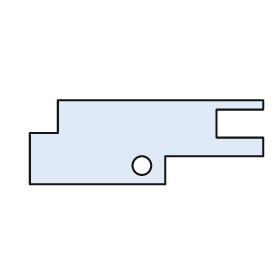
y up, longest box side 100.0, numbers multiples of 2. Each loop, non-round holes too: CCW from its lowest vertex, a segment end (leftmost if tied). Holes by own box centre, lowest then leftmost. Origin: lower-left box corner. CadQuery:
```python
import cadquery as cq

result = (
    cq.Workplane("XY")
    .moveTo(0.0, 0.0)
    .lineTo(58.0, 0.0)
    .lineTo(58.0, 12.0)
    .lineTo(100.0, 12.0)
    .lineTo(100.0, 20.0)
    .lineTo(80.0, 20.0)
    .lineTo(80.0, 32.0)
    .lineTo(100.0, 32.0)
    .lineTo(100.0, 36.0)
    .lineTo(12.0, 36.0)
    .lineTo(12.0, 22.0)
    .lineTo(0.0, 22.0)
    .close()
    .moveTo(48.0, 8.0)
    .circle(4.0)
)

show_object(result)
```